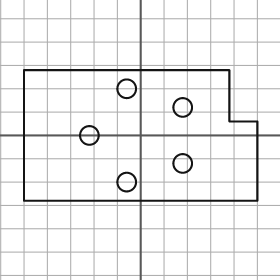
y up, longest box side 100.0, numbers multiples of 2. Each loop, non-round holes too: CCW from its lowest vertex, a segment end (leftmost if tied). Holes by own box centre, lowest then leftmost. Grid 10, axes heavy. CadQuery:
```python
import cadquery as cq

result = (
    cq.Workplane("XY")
    .moveTo(-50.0, -28.0)
    .lineTo(50.0, -28.0)
    .lineTo(50.0, 6.0)
    .lineTo(38.0, 6.0)
    .lineTo(38.0, 28.0)
    .lineTo(-50.0, 28.0)
    .close()
    .moveTo(-6.0, -20.0)
    .circle(4.0)
    .moveTo(18.0, -12.0)
    .circle(4.0)
    .moveTo(-22.0, 0.0)
    .circle(4.0)
    .moveTo(18.0, 12.0)
    .circle(4.0)
    .moveTo(-6.0, 20.0)
    .circle(4.0)
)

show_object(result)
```